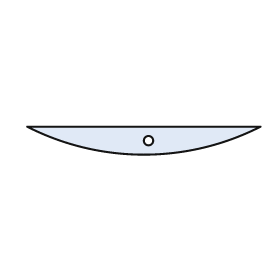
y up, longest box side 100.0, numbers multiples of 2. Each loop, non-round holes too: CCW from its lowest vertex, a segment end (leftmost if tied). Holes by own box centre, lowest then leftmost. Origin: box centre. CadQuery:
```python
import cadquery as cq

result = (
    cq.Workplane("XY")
    .moveTo(-50.0, 6.0)
    .threePointArc((0.0, -6.0), (50.0, 6.0))
    .close()
    .moveTo(2.0, 0.0)
    .circle(2.0)
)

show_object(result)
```